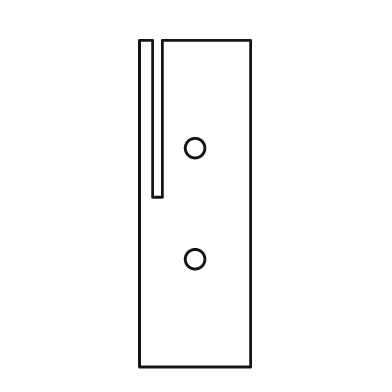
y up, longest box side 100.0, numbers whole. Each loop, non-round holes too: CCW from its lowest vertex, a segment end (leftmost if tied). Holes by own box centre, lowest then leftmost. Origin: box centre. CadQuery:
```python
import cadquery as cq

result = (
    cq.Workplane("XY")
    .moveTo(-17.0, -50.0)
    .lineTo(17.0, -50.0)
    .lineTo(17.0, 50.0)
    .lineTo(-10.0, 50.0)
    .lineTo(-10.0, 2.0)
    .lineTo(-13.0, 2.0)
    .lineTo(-13.0, 50.0)
    .lineTo(-17.0, 50.0)
    .close()
    .moveTo(0.0, -17.0)
    .circle(3.0)
    .moveTo(0.0, 17.0)
    .circle(3.0)
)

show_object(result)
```